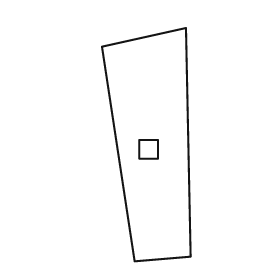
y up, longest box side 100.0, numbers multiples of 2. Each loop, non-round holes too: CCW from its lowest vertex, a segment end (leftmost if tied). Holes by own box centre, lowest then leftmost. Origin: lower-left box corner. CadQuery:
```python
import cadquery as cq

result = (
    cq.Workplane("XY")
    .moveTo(14.0, 0.0)
    .lineTo(38.0, 2.0)
    .lineTo(36.0, 100.0)
    .lineTo(0.0, 92.0)
    .close()
    .moveTo(16.0, 44.0)
    .lineTo(24.0, 44.0)
    .lineTo(24.0, 52.0)
    .lineTo(16.0, 52.0)
    .close()
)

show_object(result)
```